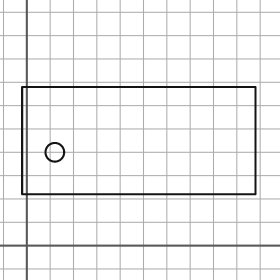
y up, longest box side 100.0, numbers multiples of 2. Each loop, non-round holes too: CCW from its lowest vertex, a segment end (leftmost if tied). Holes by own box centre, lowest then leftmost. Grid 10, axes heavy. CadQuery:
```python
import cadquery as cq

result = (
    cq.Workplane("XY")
    .moveTo(-2.0, 22.0)
    .lineTo(98.0, 22.0)
    .lineTo(98.0, 68.0)
    .lineTo(-2.0, 68.0)
    .close()
    .moveTo(12.0, 40.0)
    .circle(4.0)
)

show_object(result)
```